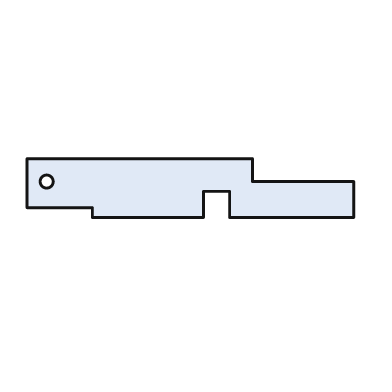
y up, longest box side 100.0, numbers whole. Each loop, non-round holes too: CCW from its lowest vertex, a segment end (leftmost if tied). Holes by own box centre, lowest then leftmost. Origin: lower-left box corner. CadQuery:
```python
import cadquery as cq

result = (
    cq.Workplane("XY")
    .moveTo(20.0, 0.0)
    .lineTo(54.0, 0.0)
    .lineTo(54.0, 8.0)
    .lineTo(62.0, 8.0)
    .lineTo(62.0, 0.0)
    .lineTo(100.0, 0.0)
    .lineTo(100.0, 11.0)
    .lineTo(69.0, 11.0)
    .lineTo(69.0, 18.0)
    .lineTo(0.0, 18.0)
    .lineTo(0.0, 3.0)
    .lineTo(20.0, 3.0)
    .close()
    .moveTo(6.0, 11.0)
    .circle(2.0)
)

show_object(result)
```